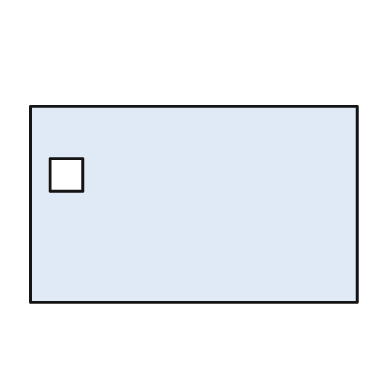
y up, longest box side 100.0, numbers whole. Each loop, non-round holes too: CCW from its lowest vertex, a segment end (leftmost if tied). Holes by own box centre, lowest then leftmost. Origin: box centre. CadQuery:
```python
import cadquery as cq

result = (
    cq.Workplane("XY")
    .moveTo(-50.0, -30.0)
    .lineTo(50.0, -30.0)
    .lineTo(50.0, 30.0)
    .lineTo(-50.0, 30.0)
    .close()
    .moveTo(-44.0, 4.0)
    .lineTo(-34.0, 4.0)
    .lineTo(-34.0, 14.0)
    .lineTo(-44.0, 14.0)
    .close()
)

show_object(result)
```